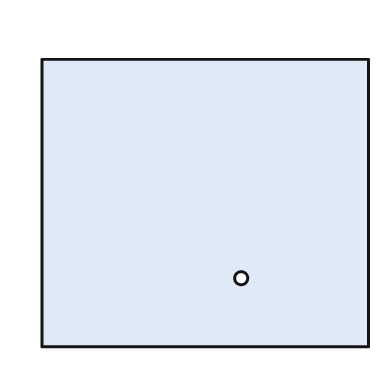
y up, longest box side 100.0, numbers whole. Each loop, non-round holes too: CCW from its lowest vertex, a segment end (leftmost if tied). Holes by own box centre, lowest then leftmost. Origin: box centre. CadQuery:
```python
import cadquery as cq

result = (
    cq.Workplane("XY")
    .moveTo(-50.0, -44.0)
    .lineTo(50.0, -44.0)
    .lineTo(50.0, 44.0)
    .lineTo(-50.0, 44.0)
    .close()
    .moveTo(11.0, -23.0)
    .circle(2.0)
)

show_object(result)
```